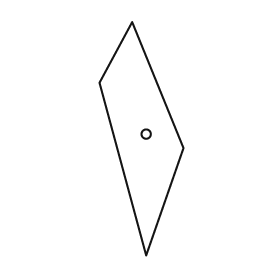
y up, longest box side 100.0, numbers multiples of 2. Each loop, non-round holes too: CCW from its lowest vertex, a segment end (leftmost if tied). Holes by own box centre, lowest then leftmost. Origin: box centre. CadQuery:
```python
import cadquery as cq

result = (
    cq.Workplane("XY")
    .moveTo(2.0, -50.0)
    .lineTo(18.0, -4.0)
    .lineTo(-4.0, 50.0)
    .lineTo(-18.0, 24.0)
    .close()
    .moveTo(2.0, 2.0)
    .circle(2.0)
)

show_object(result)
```